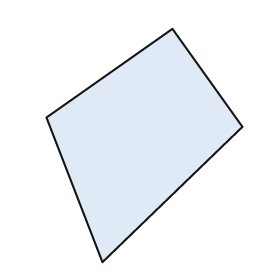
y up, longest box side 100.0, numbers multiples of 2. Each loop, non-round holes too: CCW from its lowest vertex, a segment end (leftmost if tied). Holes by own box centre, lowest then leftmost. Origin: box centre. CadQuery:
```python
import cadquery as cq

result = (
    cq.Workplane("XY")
    .moveTo(-18.0, -50.0)
    .lineTo(42.0, 8.0)
    .lineTo(12.0, 50.0)
    .lineTo(-42.0, 12.0)
    .close()
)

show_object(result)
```